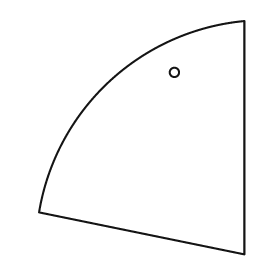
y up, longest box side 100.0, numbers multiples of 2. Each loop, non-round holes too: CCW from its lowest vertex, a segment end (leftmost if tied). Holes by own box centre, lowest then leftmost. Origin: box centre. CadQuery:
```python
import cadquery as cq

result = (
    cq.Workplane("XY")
    .moveTo(44.0, -50.0)
    .lineTo(44.0, 50.0)
    .threePointArc((-14.0, 24.0), (-44.0, -32.0))
    .close()
    .moveTo(14.0, 28.0)
    .circle(2.0)
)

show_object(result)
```